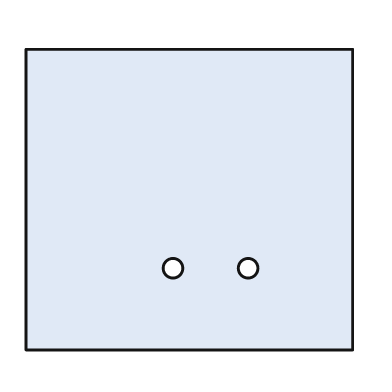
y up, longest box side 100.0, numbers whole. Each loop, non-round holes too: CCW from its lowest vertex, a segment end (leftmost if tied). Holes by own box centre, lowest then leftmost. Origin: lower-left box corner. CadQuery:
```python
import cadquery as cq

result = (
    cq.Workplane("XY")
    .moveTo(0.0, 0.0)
    .lineTo(100.0, 0.0)
    .lineTo(100.0, 92.0)
    .lineTo(0.0, 92.0)
    .close()
    .moveTo(45.0, 25.0)
    .circle(3.0)
    .moveTo(68.0, 25.0)
    .circle(3.0)
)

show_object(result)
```